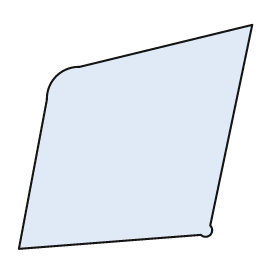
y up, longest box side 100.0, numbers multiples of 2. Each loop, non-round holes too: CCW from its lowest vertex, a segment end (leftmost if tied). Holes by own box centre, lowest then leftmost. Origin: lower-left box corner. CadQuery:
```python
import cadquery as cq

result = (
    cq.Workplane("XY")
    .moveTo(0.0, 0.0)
    .lineTo(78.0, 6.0)
    .threePointArc((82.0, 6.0), (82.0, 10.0))
    .lineTo(100.0, 96.0)
    .lineTo(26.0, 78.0)
    .threePointArc((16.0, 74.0), (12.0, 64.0))
    .close()
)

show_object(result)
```